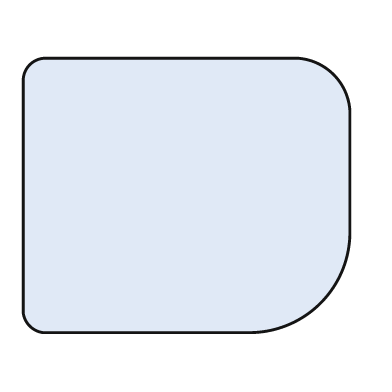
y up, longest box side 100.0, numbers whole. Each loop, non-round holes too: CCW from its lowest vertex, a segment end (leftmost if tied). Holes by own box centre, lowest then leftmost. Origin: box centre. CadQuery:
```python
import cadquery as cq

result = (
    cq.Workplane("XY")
    .moveTo(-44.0, -42.0)
    .lineTo(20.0, -42.0)
    .threePointArc((41.0, -33.0), (50.0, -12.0))
    .lineTo(50.0, 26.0)
    .threePointArc((45.0, 37.0), (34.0, 42.0))
    .lineTo(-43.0, 42.0)
    .threePointArc((-48.0, 40.0), (-50.0, 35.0))
    .lineTo(-50.0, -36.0)
    .threePointArc((-48.0, -40.0), (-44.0, -42.0))
    .close()
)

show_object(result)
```